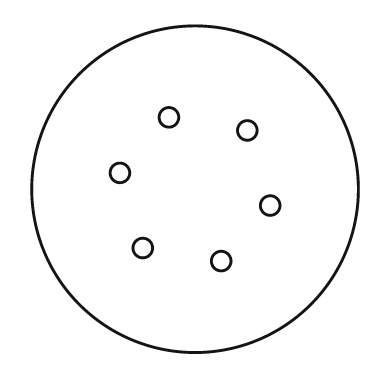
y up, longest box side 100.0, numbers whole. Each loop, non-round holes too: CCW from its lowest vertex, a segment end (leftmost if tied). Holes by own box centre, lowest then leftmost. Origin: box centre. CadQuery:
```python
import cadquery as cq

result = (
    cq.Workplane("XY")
    .moveTo(0.0, 0.0)
    .circle(50.0)
    .moveTo(8.0, -22.0)
    .circle(3.0)
    .moveTo(-16.0, -18.0)
    .circle(3.0)
    .moveTo(23.0, -5.0)
    .circle(3.0)
    .moveTo(-23.0, 5.0)
    .circle(3.0)
    .moveTo(16.0, 18.0)
    .circle(3.0)
    .moveTo(-8.0, 22.0)
    .circle(3.0)
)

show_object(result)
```